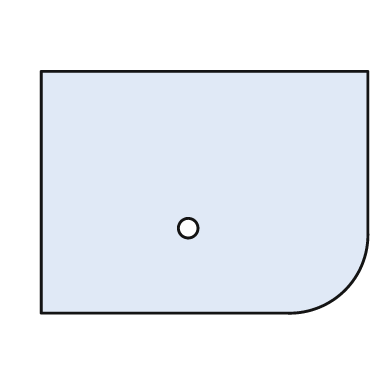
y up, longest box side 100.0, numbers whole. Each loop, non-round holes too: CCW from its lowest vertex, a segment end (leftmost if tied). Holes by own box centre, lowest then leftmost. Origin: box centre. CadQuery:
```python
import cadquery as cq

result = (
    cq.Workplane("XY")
    .moveTo(-50.0, -37.0)
    .lineTo(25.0, -37.0)
    .threePointArc((43.0, -30.0), (50.0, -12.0))
    .lineTo(50.0, 37.0)
    .lineTo(-50.0, 37.0)
    .close()
    .moveTo(-5.0, -11.0)
    .circle(3.0)
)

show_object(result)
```